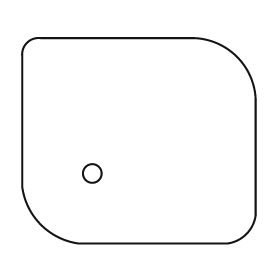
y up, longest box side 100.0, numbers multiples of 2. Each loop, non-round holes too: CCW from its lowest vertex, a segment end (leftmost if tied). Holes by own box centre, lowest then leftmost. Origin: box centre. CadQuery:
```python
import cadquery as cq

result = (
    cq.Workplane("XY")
    .moveTo(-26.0, -44.0)
    .lineTo(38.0, -44.0)
    .threePointArc((46.0, -40.0), (50.0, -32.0))
    .lineTo(50.0, 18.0)
    .threePointArc((42.0, 36.0), (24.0, 44.0))
    .lineTo(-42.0, 44.0)
    .threePointArc((-48.0, 42.0), (-50.0, 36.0))
    .lineTo(-50.0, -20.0)
    .threePointArc((-42.0, -36.0), (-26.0, -44.0))
    .close()
    .moveTo(-20.0, -14.0)
    .circle(4.0)
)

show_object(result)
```